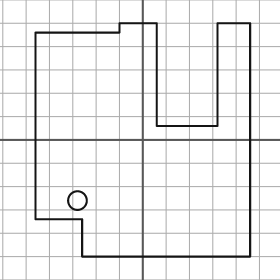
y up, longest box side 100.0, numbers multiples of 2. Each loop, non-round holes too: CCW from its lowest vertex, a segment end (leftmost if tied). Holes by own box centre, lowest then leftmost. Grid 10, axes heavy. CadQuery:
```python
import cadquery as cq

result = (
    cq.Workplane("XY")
    .moveTo(-26.0, -50.0)
    .lineTo(46.0, -50.0)
    .lineTo(46.0, 50.0)
    .lineTo(32.0, 50.0)
    .lineTo(32.0, 6.0)
    .lineTo(6.0, 6.0)
    .lineTo(6.0, 50.0)
    .lineTo(-10.0, 50.0)
    .lineTo(-10.0, 46.0)
    .lineTo(-46.0, 46.0)
    .lineTo(-46.0, -34.0)
    .lineTo(-26.0, -34.0)
    .close()
    .moveTo(-28.0, -26.0)
    .circle(4.0)
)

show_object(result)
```